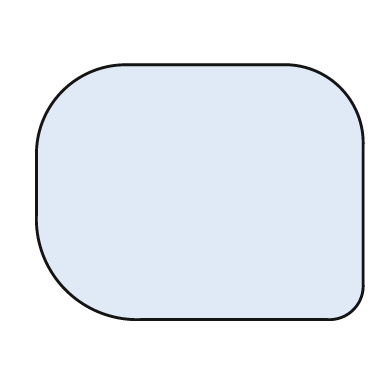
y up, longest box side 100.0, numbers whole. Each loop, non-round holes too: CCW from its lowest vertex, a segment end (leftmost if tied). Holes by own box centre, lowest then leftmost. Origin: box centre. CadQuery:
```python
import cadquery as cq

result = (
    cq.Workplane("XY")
    .moveTo(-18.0, -39.0)
    .lineTo(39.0, -39.0)
    .threePointArc((47.0, -36.0), (50.0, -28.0))
    .lineTo(50.0, 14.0)
    .threePointArc((43.0, 32.0), (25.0, 39.0))
    .lineTo(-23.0, 39.0)
    .threePointArc((-42.0, 31.0), (-50.0, 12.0))
    .lineTo(-50.0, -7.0)
    .threePointArc((-41.0, -30.0), (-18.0, -39.0))
    .close()
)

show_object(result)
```